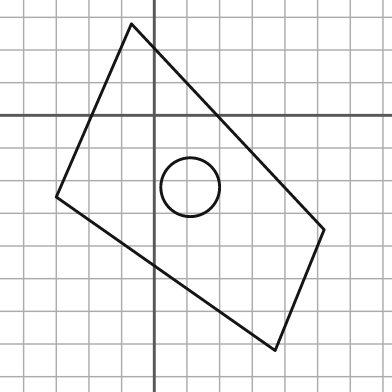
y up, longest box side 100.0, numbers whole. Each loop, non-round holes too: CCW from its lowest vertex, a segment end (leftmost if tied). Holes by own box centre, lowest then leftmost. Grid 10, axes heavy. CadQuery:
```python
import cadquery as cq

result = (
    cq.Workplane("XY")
    .moveTo(37.0, -72.0)
    .lineTo(52.0, -35.0)
    .lineTo(-7.0, 28.0)
    .lineTo(-30.0, -25.0)
    .close()
    .moveTo(11.0, -22.0)
    .circle(9.0)
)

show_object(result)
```